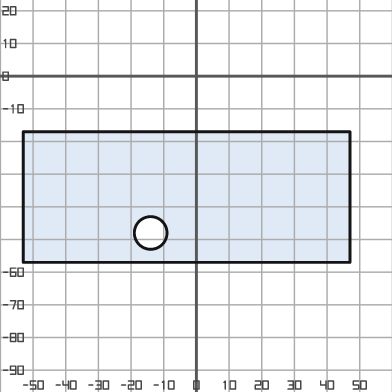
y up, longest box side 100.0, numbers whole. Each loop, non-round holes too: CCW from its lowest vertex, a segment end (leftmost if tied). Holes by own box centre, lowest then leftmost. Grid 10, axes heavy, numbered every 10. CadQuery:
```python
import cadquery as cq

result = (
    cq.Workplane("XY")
    .moveTo(-53.0, -57.0)
    .lineTo(47.0, -57.0)
    .lineTo(47.0, -17.0)
    .lineTo(-53.0, -17.0)
    .close()
    .moveTo(-14.0, -48.0)
    .circle(5.0)
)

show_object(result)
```